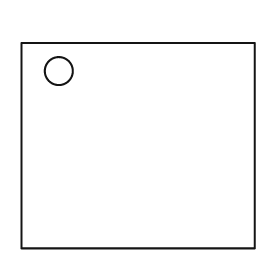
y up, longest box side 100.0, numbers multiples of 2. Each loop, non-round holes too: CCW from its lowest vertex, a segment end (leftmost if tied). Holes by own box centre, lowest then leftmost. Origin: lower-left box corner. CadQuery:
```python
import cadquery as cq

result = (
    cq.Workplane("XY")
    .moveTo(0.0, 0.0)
    .lineTo(100.0, 0.0)
    .lineTo(100.0, 88.0)
    .lineTo(0.0, 88.0)
    .close()
    .moveTo(16.0, 76.0)
    .circle(6.0)
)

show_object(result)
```